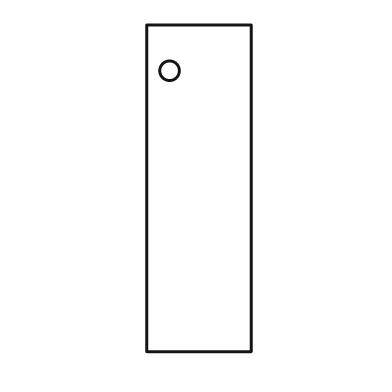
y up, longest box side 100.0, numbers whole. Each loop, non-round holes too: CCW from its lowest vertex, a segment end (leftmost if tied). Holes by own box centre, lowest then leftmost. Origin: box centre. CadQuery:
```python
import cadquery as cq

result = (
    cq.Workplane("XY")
    .moveTo(-16.0, -50.0)
    .lineTo(16.0, -50.0)
    .lineTo(16.0, 50.0)
    .lineTo(-16.0, 50.0)
    .close()
    .moveTo(-9.0, 36.0)
    .circle(3.0)
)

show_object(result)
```